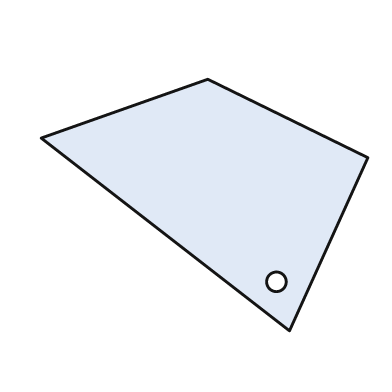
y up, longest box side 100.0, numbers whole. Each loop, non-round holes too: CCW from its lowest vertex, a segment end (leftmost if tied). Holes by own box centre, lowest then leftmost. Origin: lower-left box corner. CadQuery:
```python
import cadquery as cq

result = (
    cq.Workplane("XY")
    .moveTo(76.0, 0.0)
    .lineTo(100.0, 53.0)
    .lineTo(51.0, 77.0)
    .lineTo(0.0, 59.0)
    .close()
    .moveTo(72.0, 15.0)
    .circle(3.0)
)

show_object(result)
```